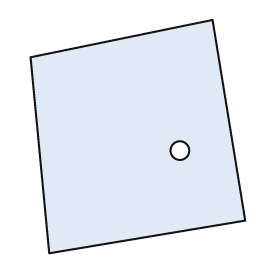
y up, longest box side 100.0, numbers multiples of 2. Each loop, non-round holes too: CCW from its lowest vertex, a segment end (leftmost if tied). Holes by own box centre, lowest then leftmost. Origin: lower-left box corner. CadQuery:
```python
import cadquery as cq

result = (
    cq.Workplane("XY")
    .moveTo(8.0, 0.0)
    .lineTo(92.0, 14.0)
    .lineTo(78.0, 100.0)
    .lineTo(0.0, 84.0)
    .close()
    .moveTo(64.0, 44.0)
    .circle(4.0)
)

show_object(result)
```